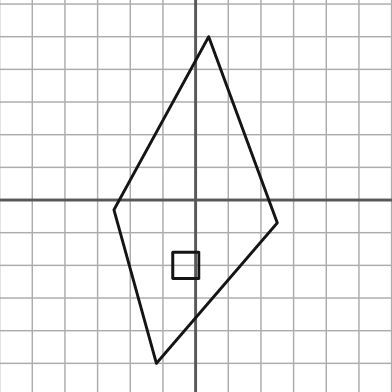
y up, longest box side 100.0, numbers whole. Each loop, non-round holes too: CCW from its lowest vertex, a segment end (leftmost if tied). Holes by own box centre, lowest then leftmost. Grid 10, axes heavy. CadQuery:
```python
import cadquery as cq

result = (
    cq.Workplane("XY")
    .moveTo(-12.0, -50.0)
    .lineTo(25.0, -7.0)
    .lineTo(4.0, 50.0)
    .lineTo(-25.0, -3.0)
    .close()
    .moveTo(-7.0, -24.0)
    .lineTo(1.0, -24.0)
    .lineTo(1.0, -16.0)
    .lineTo(-7.0, -16.0)
    .close()
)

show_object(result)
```